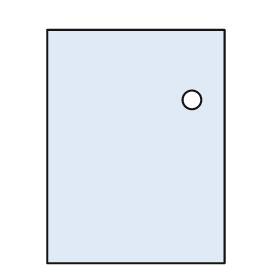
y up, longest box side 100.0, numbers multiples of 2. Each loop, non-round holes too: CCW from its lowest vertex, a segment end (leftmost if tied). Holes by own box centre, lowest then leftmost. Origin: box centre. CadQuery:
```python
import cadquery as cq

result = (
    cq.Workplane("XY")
    .moveTo(-38.0, -50.0)
    .lineTo(38.0, -50.0)
    .lineTo(38.0, 50.0)
    .lineTo(-38.0, 50.0)
    .close()
    .moveTo(24.0, 20.0)
    .circle(4.0)
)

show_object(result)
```